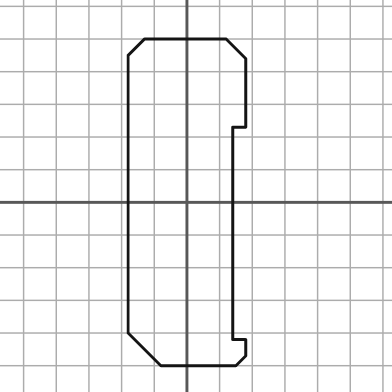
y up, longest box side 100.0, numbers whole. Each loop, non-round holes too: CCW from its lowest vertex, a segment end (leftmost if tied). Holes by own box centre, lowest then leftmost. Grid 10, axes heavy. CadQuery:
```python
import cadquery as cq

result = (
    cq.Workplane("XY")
    .moveTo(-8.0, -50.0)
    .lineTo(15.0, -50.0)
    .lineTo(18.0, -47.0)
    .lineTo(18.0, -42.0)
    .lineTo(14.0, -42.0)
    .lineTo(14.0, 23.0)
    .lineTo(18.0, 23.0)
    .lineTo(18.0, 44.0)
    .lineTo(12.0, 50.0)
    .lineTo(-13.0, 50.0)
    .lineTo(-18.0, 45.0)
    .lineTo(-18.0, -40.0)
    .close()
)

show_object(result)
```